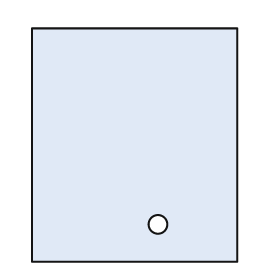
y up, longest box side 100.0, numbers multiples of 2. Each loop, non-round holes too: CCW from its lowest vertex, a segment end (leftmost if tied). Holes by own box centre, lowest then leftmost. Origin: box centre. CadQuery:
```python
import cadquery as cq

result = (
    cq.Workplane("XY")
    .moveTo(-44.0, -50.0)
    .lineTo(44.0, -50.0)
    .lineTo(44.0, 50.0)
    .lineTo(-44.0, 50.0)
    .close()
    .moveTo(10.0, -34.0)
    .circle(4.0)
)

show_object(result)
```